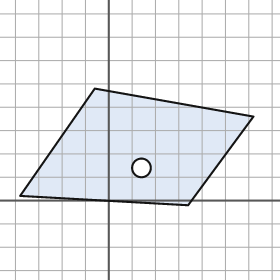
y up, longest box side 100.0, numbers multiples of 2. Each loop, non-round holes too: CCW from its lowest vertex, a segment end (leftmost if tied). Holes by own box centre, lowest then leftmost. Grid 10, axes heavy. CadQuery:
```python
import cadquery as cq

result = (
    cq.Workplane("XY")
    .moveTo(34.0, -2.0)
    .lineTo(62.0, 36.0)
    .lineTo(-6.0, 48.0)
    .lineTo(-38.0, 2.0)
    .close()
    .moveTo(14.0, 14.0)
    .circle(4.0)
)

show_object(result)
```